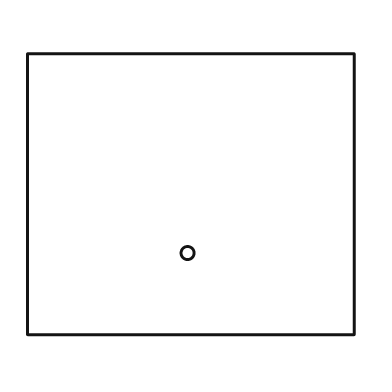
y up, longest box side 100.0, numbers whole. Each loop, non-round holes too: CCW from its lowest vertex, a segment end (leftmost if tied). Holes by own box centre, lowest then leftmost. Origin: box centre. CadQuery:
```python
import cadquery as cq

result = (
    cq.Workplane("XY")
    .moveTo(-50.0, -43.0)
    .lineTo(50.0, -43.0)
    .lineTo(50.0, 43.0)
    .lineTo(-50.0, 43.0)
    .close()
    .moveTo(-1.0, -18.0)
    .circle(2.0)
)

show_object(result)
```